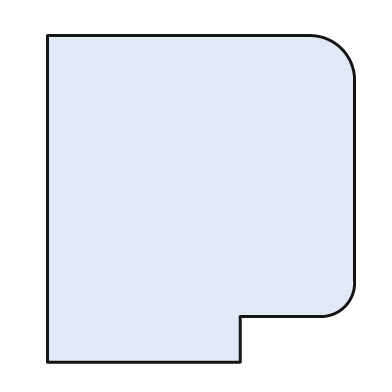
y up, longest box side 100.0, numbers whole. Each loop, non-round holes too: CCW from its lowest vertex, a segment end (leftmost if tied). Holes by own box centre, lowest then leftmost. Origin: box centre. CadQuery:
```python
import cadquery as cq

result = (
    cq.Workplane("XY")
    .moveTo(-47.0, -50.0)
    .lineTo(12.0, -50.0)
    .lineTo(12.0, -36.0)
    .lineTo(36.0, -36.0)
    .threePointArc((44.0, -33.0), (47.0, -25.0))
    .lineTo(47.0, 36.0)
    .threePointArc((43.0, 46.0), (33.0, 50.0))
    .lineTo(-47.0, 50.0)
    .close()
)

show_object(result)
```